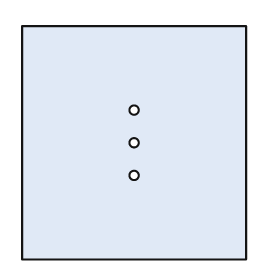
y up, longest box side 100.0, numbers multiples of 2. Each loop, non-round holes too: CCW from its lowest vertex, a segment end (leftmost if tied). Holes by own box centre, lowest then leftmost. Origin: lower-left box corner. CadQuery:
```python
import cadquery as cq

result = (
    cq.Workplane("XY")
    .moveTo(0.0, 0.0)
    .lineTo(96.0, 0.0)
    .lineTo(96.0, 100.0)
    .lineTo(0.0, 100.0)
    .close()
    .moveTo(48.0, 36.0)
    .circle(2.0)
    .moveTo(48.0, 50.0)
    .circle(2.0)
    .moveTo(48.0, 64.0)
    .circle(2.0)
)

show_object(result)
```